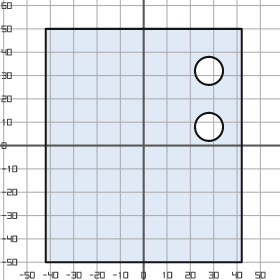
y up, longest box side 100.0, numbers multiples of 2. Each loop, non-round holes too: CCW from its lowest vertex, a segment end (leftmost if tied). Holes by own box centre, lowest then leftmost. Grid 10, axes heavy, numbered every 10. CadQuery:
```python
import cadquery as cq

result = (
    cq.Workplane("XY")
    .moveTo(-42.0, -50.0)
    .lineTo(42.0, -50.0)
    .lineTo(42.0, 50.0)
    .lineTo(-42.0, 50.0)
    .close()
    .moveTo(28.0, 8.0)
    .circle(6.0)
    .moveTo(28.0, 32.0)
    .circle(6.0)
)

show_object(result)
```